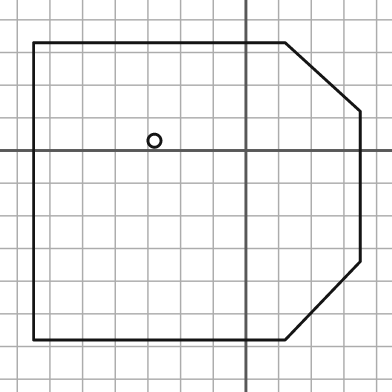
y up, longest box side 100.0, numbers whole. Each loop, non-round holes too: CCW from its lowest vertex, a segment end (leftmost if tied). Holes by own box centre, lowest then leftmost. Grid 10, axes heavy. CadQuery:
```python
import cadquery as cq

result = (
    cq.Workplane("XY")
    .moveTo(-65.0, -58.0)
    .lineTo(12.0, -58.0)
    .lineTo(35.0, -34.0)
    .lineTo(35.0, 12.0)
    .lineTo(12.0, 33.0)
    .lineTo(-65.0, 33.0)
    .close()
    .moveTo(-28.0, 3.0)
    .circle(2.0)
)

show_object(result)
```